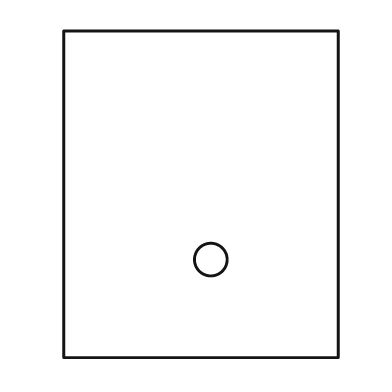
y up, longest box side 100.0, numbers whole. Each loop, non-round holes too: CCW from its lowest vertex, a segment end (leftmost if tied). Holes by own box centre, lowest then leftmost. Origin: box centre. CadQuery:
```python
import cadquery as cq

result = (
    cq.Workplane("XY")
    .moveTo(-42.0, -50.0)
    .lineTo(42.0, -50.0)
    .lineTo(42.0, 50.0)
    .lineTo(-42.0, 50.0)
    .close()
    .moveTo(3.0, -20.0)
    .circle(5.0)
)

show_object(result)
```